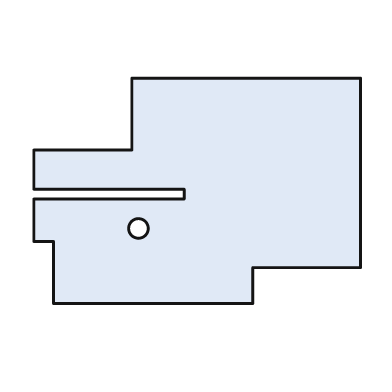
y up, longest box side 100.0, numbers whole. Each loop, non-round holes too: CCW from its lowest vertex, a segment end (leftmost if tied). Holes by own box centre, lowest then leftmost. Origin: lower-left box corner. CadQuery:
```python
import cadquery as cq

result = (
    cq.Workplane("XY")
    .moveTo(6.0, 0.0)
    .lineTo(67.0, 0.0)
    .lineTo(67.0, 11.0)
    .lineTo(100.0, 11.0)
    .lineTo(100.0, 69.0)
    .lineTo(30.0, 69.0)
    .lineTo(30.0, 47.0)
    .lineTo(0.0, 47.0)
    .lineTo(0.0, 35.0)
    .lineTo(46.0, 35.0)
    .lineTo(46.0, 32.0)
    .lineTo(0.0, 32.0)
    .lineTo(0.0, 19.0)
    .lineTo(6.0, 19.0)
    .close()
    .moveTo(32.0, 23.0)
    .circle(3.0)
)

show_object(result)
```